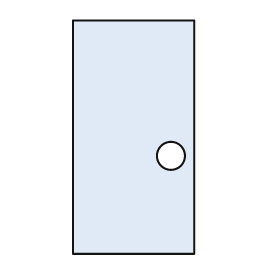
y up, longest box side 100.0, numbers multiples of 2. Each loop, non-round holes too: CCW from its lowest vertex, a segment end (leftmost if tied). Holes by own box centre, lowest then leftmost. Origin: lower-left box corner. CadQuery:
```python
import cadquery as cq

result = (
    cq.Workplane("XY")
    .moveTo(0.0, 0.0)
    .lineTo(52.0, 0.0)
    .lineTo(52.0, 100.0)
    .lineTo(0.0, 100.0)
    .close()
    .moveTo(42.0, 42.0)
    .circle(6.0)
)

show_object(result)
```